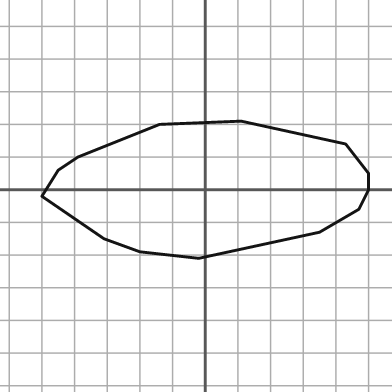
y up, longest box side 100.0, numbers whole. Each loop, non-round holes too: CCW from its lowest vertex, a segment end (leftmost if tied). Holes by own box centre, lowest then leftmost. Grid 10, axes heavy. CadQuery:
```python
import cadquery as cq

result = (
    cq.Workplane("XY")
    .moveTo(-2.0, -21.0)
    .lineTo(35.0, -13.0)
    .lineTo(47.0, -6.0)
    .lineTo(50.0, 0.0)
    .lineTo(50.0, 5.0)
    .lineTo(43.0, 14.0)
    .lineTo(11.0, 21.0)
    .lineTo(-14.0, 20.0)
    .lineTo(-39.0, 10.0)
    .lineTo(-45.0, 6.0)
    .lineTo(-50.0, -2.0)
    .lineTo(-31.0, -15.0)
    .lineTo(-20.0, -19.0)
    .close()
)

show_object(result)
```